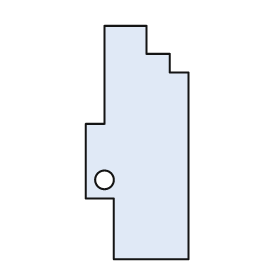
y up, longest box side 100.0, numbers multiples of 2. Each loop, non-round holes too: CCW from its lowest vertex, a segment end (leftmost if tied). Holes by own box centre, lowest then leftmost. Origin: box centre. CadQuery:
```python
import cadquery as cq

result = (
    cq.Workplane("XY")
    .moveTo(-10.0, -50.0)
    .lineTo(22.0, -50.0)
    .lineTo(22.0, 30.0)
    .lineTo(14.0, 30.0)
    .lineTo(14.0, 38.0)
    .lineTo(4.0, 38.0)
    .lineTo(4.0, 50.0)
    .lineTo(-14.0, 50.0)
    .lineTo(-14.0, 8.0)
    .lineTo(-22.0, 8.0)
    .lineTo(-22.0, -24.0)
    .lineTo(-10.0, -24.0)
    .close()
    .moveTo(-14.0, -16.0)
    .circle(4.0)
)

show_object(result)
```